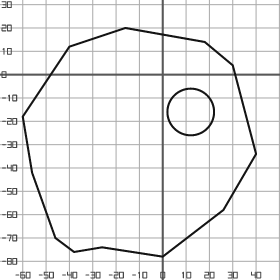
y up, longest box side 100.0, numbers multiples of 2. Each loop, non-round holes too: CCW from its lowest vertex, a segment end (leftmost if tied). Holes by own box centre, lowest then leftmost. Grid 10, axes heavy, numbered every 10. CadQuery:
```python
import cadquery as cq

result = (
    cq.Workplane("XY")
    .moveTo(0.0, -78.0)
    .lineTo(26.0, -58.0)
    .lineTo(40.0, -34.0)
    .lineTo(30.0, 4.0)
    .lineTo(18.0, 14.0)
    .lineTo(-16.0, 20.0)
    .lineTo(-40.0, 12.0)
    .lineTo(-60.0, -18.0)
    .lineTo(-56.0, -42.0)
    .lineTo(-46.0, -70.0)
    .lineTo(-38.0, -76.0)
    .lineTo(-26.0, -74.0)
    .close()
    .moveTo(12.0, -16.0)
    .circle(10.0)
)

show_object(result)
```